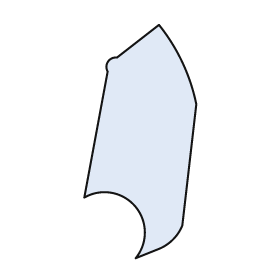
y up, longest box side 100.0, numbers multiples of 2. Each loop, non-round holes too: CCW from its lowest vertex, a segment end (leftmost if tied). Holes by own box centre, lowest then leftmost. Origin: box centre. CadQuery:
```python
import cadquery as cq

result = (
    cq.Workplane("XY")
    .moveTo(-2.0, -50.0)
    .lineTo(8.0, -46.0)
    .threePointArc((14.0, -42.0), (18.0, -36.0))
    .lineTo(24.0, 16.0)
    .threePointArc((18.0, 34.0), (8.0, 50.0))
    .lineTo(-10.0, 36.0)
    .threePointArc((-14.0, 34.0), (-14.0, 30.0))
    .lineTo(-24.0, -24.0)
    .threePointArc((-2.0, -28.0), (-2.0, -50.0))
    .close()
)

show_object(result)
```